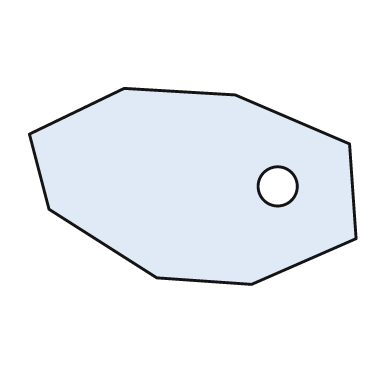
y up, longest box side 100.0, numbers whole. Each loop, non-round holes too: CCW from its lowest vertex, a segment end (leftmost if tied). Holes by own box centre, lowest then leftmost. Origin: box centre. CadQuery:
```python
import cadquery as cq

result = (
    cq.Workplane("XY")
    .moveTo(18.0, -30.0)
    .lineTo(50.0, -16.0)
    .lineTo(48.0, 13.0)
    .lineTo(13.0, 28.0)
    .lineTo(-21.0, 30.0)
    .lineTo(-50.0, 16.0)
    .lineTo(-44.0, -7.0)
    .lineTo(-11.0, -28.0)
    .close()
    .moveTo(26.0, 0.0)
    .circle(6.0)
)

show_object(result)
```